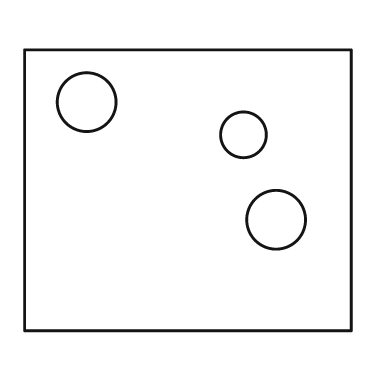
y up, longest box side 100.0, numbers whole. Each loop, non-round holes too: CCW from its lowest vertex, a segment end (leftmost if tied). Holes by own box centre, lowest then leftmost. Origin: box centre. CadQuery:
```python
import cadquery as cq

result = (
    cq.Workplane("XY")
    .moveTo(-50.0, -43.0)
    .lineTo(50.0, -43.0)
    .lineTo(50.0, 43.0)
    .lineTo(-50.0, 43.0)
    .close()
    .moveTo(27.0, -9.0)
    .circle(9.0)
    .moveTo(17.0, 17.0)
    .circle(7.0)
    .moveTo(-31.0, 27.0)
    .circle(9.0)
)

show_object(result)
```